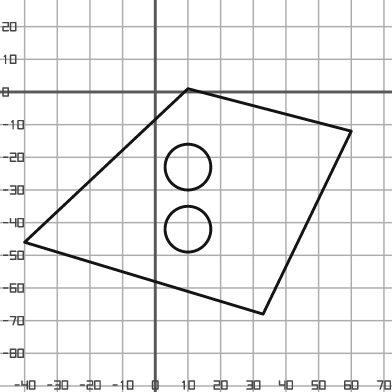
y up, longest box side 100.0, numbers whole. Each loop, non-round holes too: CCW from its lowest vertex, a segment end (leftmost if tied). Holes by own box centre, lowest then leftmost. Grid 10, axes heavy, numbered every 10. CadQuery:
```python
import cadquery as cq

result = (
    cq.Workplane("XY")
    .moveTo(33.0, -68.0)
    .lineTo(60.0, -12.0)
    .lineTo(10.0, 1.0)
    .lineTo(-40.0, -46.0)
    .close()
    .moveTo(10.0, -42.0)
    .circle(7.0)
    .moveTo(10.0, -23.0)
    .circle(7.0)
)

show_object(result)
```